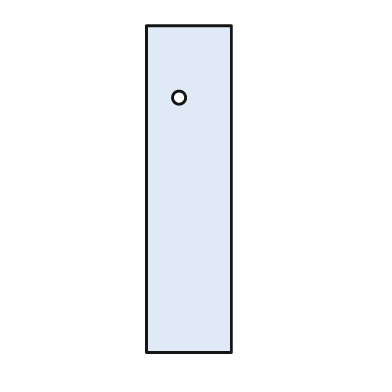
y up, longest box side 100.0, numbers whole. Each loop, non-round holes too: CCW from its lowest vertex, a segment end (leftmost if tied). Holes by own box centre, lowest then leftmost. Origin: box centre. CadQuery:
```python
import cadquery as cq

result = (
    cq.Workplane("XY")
    .moveTo(-13.0, -50.0)
    .lineTo(13.0, -50.0)
    .lineTo(13.0, 50.0)
    .lineTo(-13.0, 50.0)
    .close()
    .moveTo(-3.0, 28.0)
    .circle(2.0)
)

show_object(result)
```